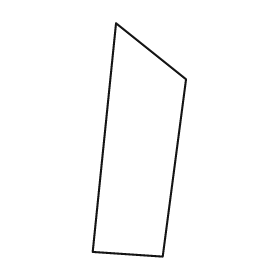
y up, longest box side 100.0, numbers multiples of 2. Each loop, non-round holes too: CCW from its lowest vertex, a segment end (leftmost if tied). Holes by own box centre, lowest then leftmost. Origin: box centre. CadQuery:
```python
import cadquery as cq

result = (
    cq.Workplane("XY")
    .moveTo(10.0, -50.0)
    .lineTo(20.0, 26.0)
    .lineTo(-10.0, 50.0)
    .lineTo(-20.0, -48.0)
    .close()
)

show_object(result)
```